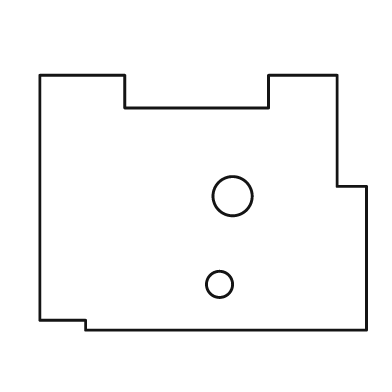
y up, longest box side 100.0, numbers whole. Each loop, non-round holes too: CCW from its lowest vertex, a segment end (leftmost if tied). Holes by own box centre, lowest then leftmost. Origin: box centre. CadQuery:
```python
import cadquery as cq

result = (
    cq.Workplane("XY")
    .moveTo(-36.0, -39.0)
    .lineTo(50.0, -39.0)
    .lineTo(50.0, 5.0)
    .lineTo(41.0, 5.0)
    .lineTo(41.0, 39.0)
    .lineTo(20.0, 39.0)
    .lineTo(20.0, 29.0)
    .lineTo(-24.0, 29.0)
    .lineTo(-24.0, 39.0)
    .lineTo(-50.0, 39.0)
    .lineTo(-50.0, -36.0)
    .lineTo(-36.0, -36.0)
    .close()
    .moveTo(5.0, -25.0)
    .circle(4.0)
    .moveTo(9.0, 2.0)
    .circle(6.0)
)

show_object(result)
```